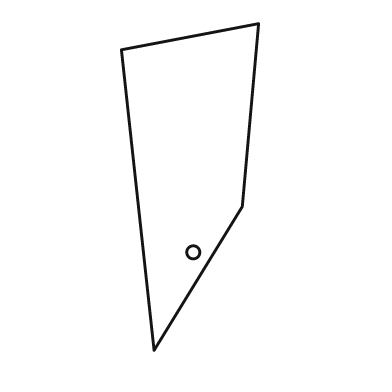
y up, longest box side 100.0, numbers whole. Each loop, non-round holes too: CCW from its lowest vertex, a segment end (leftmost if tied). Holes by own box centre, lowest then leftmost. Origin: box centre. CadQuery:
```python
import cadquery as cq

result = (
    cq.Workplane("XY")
    .moveTo(-11.0, -50.0)
    .lineTo(16.0, -6.0)
    .lineTo(21.0, 50.0)
    .lineTo(-21.0, 42.0)
    .close()
    .moveTo(1.0, -20.0)
    .circle(2.0)
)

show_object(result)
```